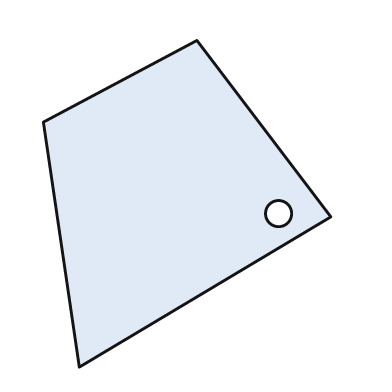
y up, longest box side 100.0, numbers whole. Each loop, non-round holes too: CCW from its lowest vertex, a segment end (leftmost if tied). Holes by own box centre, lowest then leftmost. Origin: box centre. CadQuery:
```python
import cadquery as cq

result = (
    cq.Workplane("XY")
    .moveTo(-33.0, -50.0)
    .lineTo(44.0, -4.0)
    .lineTo(3.0, 50.0)
    .lineTo(-44.0, 25.0)
    .close()
    .moveTo(28.0, -3.0)
    .circle(4.0)
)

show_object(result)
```